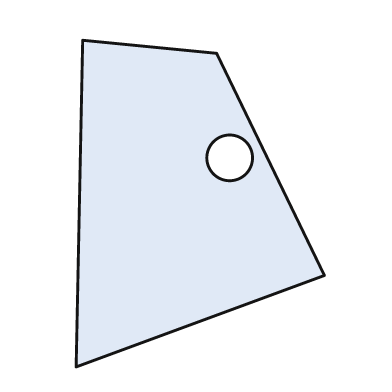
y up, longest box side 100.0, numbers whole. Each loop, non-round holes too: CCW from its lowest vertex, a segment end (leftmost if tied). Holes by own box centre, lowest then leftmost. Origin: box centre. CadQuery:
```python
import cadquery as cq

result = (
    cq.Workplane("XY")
    .moveTo(-38.0, -50.0)
    .lineTo(38.0, -22.0)
    .lineTo(5.0, 46.0)
    .lineTo(-36.0, 50.0)
    .close()
    .moveTo(9.0, 14.0)
    .circle(7.0)
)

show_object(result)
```